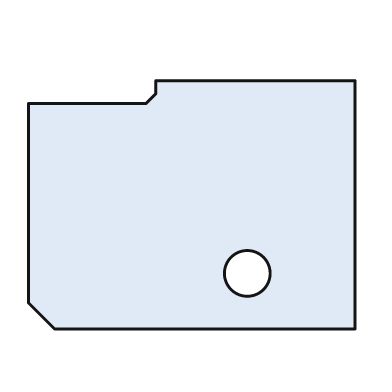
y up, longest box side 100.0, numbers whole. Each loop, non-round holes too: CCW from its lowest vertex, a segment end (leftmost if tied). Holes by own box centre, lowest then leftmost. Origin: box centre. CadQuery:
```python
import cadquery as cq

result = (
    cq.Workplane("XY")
    .moveTo(-42.0, -38.0)
    .lineTo(50.0, -38.0)
    .lineTo(50.0, 38.0)
    .lineTo(-11.0, 38.0)
    .lineTo(-11.0, 34.0)
    .lineTo(-14.0, 31.0)
    .lineTo(-50.0, 31.0)
    .lineTo(-50.0, -30.0)
    .close()
    .moveTo(17.0, -21.0)
    .circle(7.0)
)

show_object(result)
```